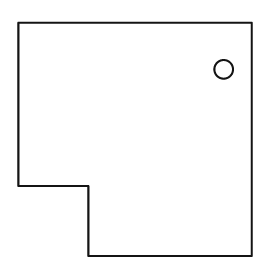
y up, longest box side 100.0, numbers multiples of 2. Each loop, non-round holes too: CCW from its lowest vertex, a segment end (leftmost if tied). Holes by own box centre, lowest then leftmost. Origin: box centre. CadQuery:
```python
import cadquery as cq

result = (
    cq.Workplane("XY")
    .moveTo(-20.0, -50.0)
    .lineTo(50.0, -50.0)
    .lineTo(50.0, 50.0)
    .lineTo(-50.0, 50.0)
    .lineTo(-50.0, -20.0)
    .lineTo(-20.0, -20.0)
    .close()
    .moveTo(38.0, 30.0)
    .circle(4.0)
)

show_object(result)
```